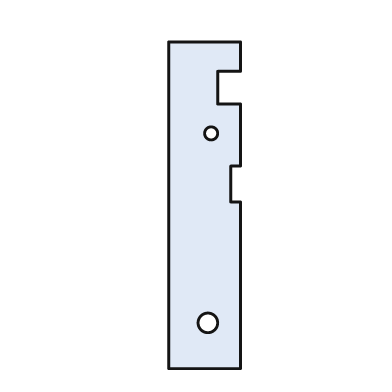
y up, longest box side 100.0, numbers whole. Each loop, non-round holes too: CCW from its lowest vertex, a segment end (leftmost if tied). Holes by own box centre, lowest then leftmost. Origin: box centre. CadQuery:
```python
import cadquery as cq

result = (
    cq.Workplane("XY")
    .moveTo(-11.0, -50.0)
    .lineTo(11.0, -50.0)
    .lineTo(11.0, 1.0)
    .lineTo(8.0, 1.0)
    .lineTo(8.0, 12.0)
    .lineTo(11.0, 12.0)
    .lineTo(11.0, 31.0)
    .lineTo(4.0, 31.0)
    .lineTo(4.0, 41.0)
    .lineTo(11.0, 41.0)
    .lineTo(11.0, 50.0)
    .lineTo(-11.0, 50.0)
    .close()
    .moveTo(1.0, -36.0)
    .circle(3.0)
    .moveTo(2.0, 22.0)
    .circle(2.0)
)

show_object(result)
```